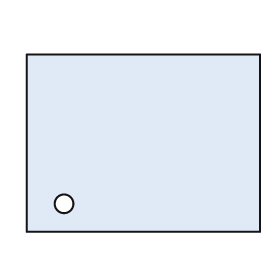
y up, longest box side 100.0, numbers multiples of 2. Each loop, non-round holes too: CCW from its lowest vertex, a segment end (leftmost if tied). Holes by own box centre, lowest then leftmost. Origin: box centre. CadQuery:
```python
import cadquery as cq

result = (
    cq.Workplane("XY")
    .moveTo(-50.0, -38.0)
    .lineTo(50.0, -38.0)
    .lineTo(50.0, 38.0)
    .lineTo(-50.0, 38.0)
    .close()
    .moveTo(-34.0, -26.0)
    .circle(4.0)
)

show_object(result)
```